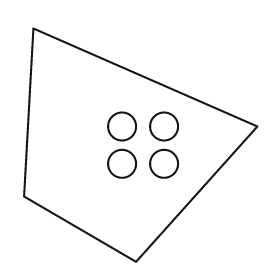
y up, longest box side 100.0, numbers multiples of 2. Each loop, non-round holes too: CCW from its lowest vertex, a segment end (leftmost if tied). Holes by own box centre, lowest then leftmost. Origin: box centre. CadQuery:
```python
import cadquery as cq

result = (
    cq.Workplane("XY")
    .moveTo(-2.0, -50.0)
    .lineTo(50.0, 8.0)
    .lineTo(-46.0, 50.0)
    .lineTo(-50.0, -22.0)
    .close()
    .moveTo(-8.0, -8.0)
    .circle(6.0)
    .moveTo(10.0, -8.0)
    .circle(6.0)
    .moveTo(-8.0, 8.0)
    .circle(6.0)
    .moveTo(10.0, 8.0)
    .circle(6.0)
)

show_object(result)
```